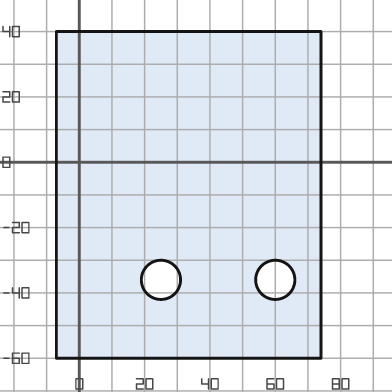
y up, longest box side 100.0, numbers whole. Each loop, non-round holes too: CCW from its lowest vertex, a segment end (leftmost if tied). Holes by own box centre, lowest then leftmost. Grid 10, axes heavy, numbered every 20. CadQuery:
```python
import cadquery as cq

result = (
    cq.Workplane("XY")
    .moveTo(-7.0, -60.0)
    .lineTo(74.0, -60.0)
    .lineTo(74.0, 40.0)
    .lineTo(-7.0, 40.0)
    .close()
    .moveTo(25.0, -36.0)
    .circle(6.0)
    .moveTo(60.0, -36.0)
    .circle(6.0)
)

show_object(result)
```